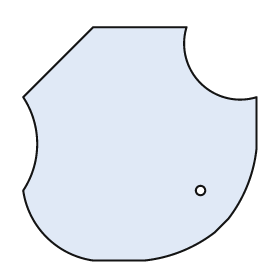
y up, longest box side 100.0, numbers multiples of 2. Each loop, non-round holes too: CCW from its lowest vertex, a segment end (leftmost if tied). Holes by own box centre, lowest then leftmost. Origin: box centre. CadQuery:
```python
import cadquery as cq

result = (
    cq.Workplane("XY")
    .moveTo(-20.0, -50.0)
    .lineTo(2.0, -50.0)
    .threePointArc((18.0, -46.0), (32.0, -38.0))
    .lineTo(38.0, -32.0)
    .threePointArc((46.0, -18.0), (50.0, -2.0))
    .lineTo(50.0, 20.0)
    .threePointArc((26.0, 26.0), (20.0, 50.0))
    .lineTo(-20.0, 50.0)
    .lineTo(-50.0, 20.0)
    .threePointArc((-44.0, 0.0), (-50.0, -20.0))
    .threePointArc((-40.0, -40.0), (-20.0, -50.0))
    .close()
    .moveTo(26.0, -20.0)
    .circle(2.0)
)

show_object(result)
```